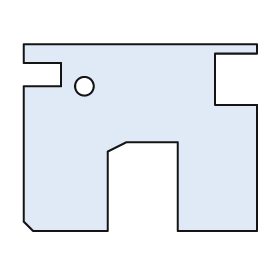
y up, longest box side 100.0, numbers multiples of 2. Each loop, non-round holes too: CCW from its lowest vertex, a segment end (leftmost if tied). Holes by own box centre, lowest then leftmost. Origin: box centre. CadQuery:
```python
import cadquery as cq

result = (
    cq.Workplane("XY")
    .moveTo(-46.0, -40.0)
    .lineTo(-14.0, -40.0)
    .lineTo(-14.0, -6.0)
    .lineTo(-6.0, -2.0)
    .lineTo(16.0, -2.0)
    .lineTo(16.0, -40.0)
    .lineTo(50.0, -40.0)
    .lineTo(50.0, 14.0)
    .lineTo(32.0, 14.0)
    .lineTo(32.0, 36.0)
    .lineTo(50.0, 36.0)
    .lineTo(50.0, 40.0)
    .lineTo(-50.0, 40.0)
    .lineTo(-50.0, 32.0)
    .lineTo(-34.0, 32.0)
    .lineTo(-34.0, 22.0)
    .lineTo(-50.0, 22.0)
    .lineTo(-50.0, -36.0)
    .close()
    .moveTo(-24.0, 22.0)
    .circle(4.0)
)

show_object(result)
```